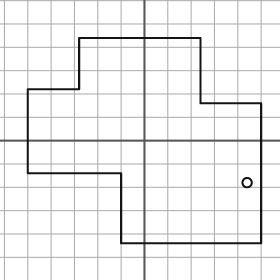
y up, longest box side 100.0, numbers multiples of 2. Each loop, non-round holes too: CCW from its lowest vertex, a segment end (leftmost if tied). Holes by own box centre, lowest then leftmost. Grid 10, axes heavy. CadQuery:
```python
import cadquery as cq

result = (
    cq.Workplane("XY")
    .moveTo(-10.0, -44.0)
    .lineTo(50.0, -44.0)
    .lineTo(50.0, 16.0)
    .lineTo(24.0, 16.0)
    .lineTo(24.0, 44.0)
    .lineTo(-28.0, 44.0)
    .lineTo(-28.0, 22.0)
    .lineTo(-50.0, 22.0)
    .lineTo(-50.0, -14.0)
    .lineTo(-10.0, -14.0)
    .close()
    .moveTo(44.0, -18.0)
    .circle(2.0)
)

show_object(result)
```